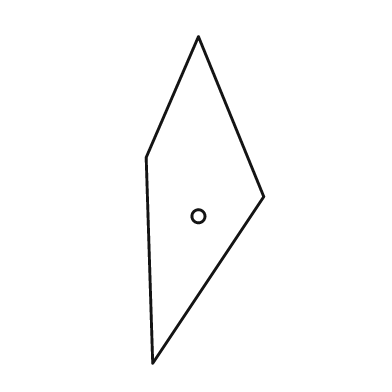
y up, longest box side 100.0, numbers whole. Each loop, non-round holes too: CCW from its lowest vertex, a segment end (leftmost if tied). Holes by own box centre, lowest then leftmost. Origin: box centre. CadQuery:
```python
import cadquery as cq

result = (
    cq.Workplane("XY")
    .moveTo(-16.0, -50.0)
    .lineTo(18.0, 1.0)
    .lineTo(-2.0, 50.0)
    .lineTo(-18.0, 13.0)
    .close()
    .moveTo(-2.0, -5.0)
    .circle(2.0)
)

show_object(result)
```